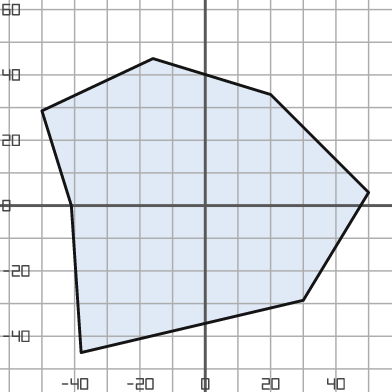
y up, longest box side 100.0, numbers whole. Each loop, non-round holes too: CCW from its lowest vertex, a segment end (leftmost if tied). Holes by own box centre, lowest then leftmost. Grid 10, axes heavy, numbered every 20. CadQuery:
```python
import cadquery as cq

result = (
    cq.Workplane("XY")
    .moveTo(-38.0, -45.0)
    .lineTo(30.0, -29.0)
    .lineTo(50.0, 4.0)
    .lineTo(20.0, 34.0)
    .lineTo(-16.0, 45.0)
    .lineTo(-50.0, 29.0)
    .lineTo(-41.0, 0.0)
    .close()
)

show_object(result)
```